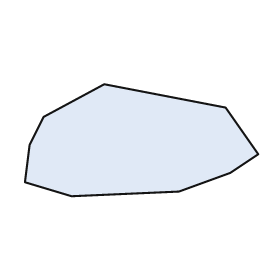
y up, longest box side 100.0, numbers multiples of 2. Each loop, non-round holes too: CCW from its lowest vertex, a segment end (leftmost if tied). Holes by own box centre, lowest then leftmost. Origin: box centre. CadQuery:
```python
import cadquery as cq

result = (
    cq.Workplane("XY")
    .moveTo(-30.0, -24.0)
    .lineTo(16.0, -22.0)
    .lineTo(38.0, -14.0)
    .lineTo(50.0, -6.0)
    .lineTo(36.0, 14.0)
    .lineTo(-16.0, 24.0)
    .lineTo(-42.0, 10.0)
    .lineTo(-48.0, -2.0)
    .lineTo(-50.0, -18.0)
    .close()
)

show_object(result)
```